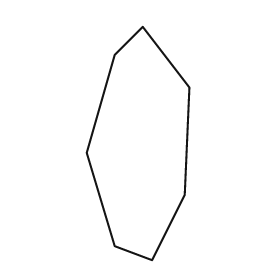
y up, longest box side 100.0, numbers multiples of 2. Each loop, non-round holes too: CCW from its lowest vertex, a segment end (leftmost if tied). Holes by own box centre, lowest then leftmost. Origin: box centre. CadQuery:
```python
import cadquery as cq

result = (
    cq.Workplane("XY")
    .moveTo(6.0, -50.0)
    .lineTo(20.0, -22.0)
    .lineTo(22.0, 24.0)
    .lineTo(2.0, 50.0)
    .lineTo(-10.0, 38.0)
    .lineTo(-22.0, -4.0)
    .lineTo(-10.0, -44.0)
    .close()
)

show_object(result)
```